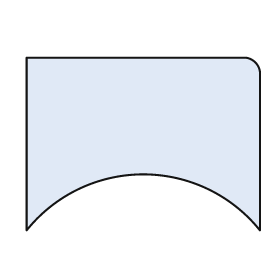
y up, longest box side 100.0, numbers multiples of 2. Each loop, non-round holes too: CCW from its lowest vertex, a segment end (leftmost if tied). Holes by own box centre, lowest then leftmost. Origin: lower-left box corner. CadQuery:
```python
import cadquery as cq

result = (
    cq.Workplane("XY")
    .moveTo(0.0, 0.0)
    .threePointArc((50.0, 24.0), (100.0, 0.0))
    .lineTo(100.0, 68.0)
    .threePointArc((98.0, 72.0), (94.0, 74.0))
    .lineTo(0.0, 74.0)
    .close()
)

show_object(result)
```